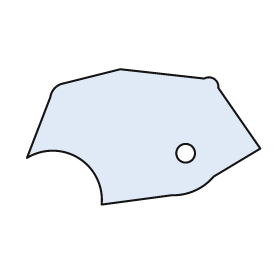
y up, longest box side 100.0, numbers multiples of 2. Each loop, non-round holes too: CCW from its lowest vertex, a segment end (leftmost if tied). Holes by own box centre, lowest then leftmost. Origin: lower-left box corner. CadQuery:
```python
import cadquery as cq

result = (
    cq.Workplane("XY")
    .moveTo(32.0, 0.0)
    .lineTo(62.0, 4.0)
    .threePointArc((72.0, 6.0), (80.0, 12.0))
    .lineTo(100.0, 24.0)
    .lineTo(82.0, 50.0)
    .threePointArc((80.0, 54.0), (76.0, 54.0))
    .lineTo(40.0, 58.0)
    .lineTo(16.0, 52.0)
    .threePointArc((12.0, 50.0), (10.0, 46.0))
    .lineTo(0.0, 20.0)
    .threePointArc((22.0, 20.0), (32.0, 0.0))
    .close()
    .moveTo(68.0, 22.0)
    .circle(4.0)
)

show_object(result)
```